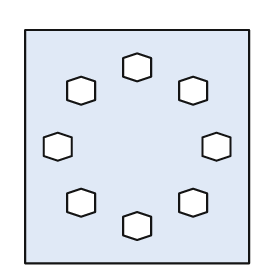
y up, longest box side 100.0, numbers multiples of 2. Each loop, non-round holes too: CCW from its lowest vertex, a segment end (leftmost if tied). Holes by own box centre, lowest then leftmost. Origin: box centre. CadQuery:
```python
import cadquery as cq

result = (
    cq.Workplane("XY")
    .moveTo(-48.0, -50.0)
    .lineTo(48.0, -50.0)
    .lineTo(48.0, 50.0)
    .lineTo(-48.0, 50.0)
    .close()
    .moveTo(0.0, -40.0)
    .lineTo(6.0, -38.0)
    .lineTo(6.0, -30.0)
    .lineTo(0.0, -28.0)
    .lineTo(-6.0, -30.0)
    .lineTo(-6.0, -38.0)
    .close()
    .moveTo(-24.0, -30.0)
    .lineTo(-18.0, -28.0)
    .lineTo(-18.0, -20.0)
    .lineTo(-24.0, -18.0)
    .lineTo(-30.0, -20.0)
    .lineTo(-30.0, -28.0)
    .close()
    .moveTo(24.0, -30.0)
    .lineTo(30.0, -28.0)
    .lineTo(30.0, -20.0)
    .lineTo(24.0, -18.0)
    .lineTo(18.0, -20.0)
    .lineTo(18.0, -28.0)
    .close()
    .moveTo(-34.0, -6.0)
    .lineTo(-28.0, -4.0)
    .lineTo(-28.0, 4.0)
    .lineTo(-34.0, 6.0)
    .lineTo(-40.0, 4.0)
    .lineTo(-40.0, -4.0)
    .close()
    .moveTo(34.0, -6.0)
    .lineTo(40.0, -4.0)
    .lineTo(40.0, 4.0)
    .lineTo(34.0, 6.0)
    .lineTo(28.0, 4.0)
    .lineTo(28.0, -4.0)
    .close()
    .moveTo(-24.0, 18.0)
    .lineTo(-18.0, 20.0)
    .lineTo(-18.0, 28.0)
    .lineTo(-24.0, 30.0)
    .lineTo(-30.0, 28.0)
    .lineTo(-30.0, 20.0)
    .close()
    .moveTo(24.0, 18.0)
    .lineTo(30.0, 20.0)
    .lineTo(30.0, 28.0)
    .lineTo(24.0, 30.0)
    .lineTo(18.0, 28.0)
    .lineTo(18.0, 20.0)
    .close()
    .moveTo(0.0, 28.0)
    .lineTo(6.0, 30.0)
    .lineTo(6.0, 38.0)
    .lineTo(0.0, 40.0)
    .lineTo(-6.0, 38.0)
    .lineTo(-6.0, 30.0)
    .close()
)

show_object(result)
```